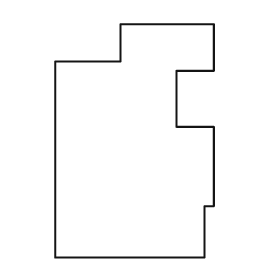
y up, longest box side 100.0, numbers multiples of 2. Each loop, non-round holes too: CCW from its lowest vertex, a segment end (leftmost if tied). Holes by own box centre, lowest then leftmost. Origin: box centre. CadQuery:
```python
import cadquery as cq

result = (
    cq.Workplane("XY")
    .moveTo(-34.0, -50.0)
    .lineTo(30.0, -50.0)
    .lineTo(30.0, -28.0)
    .lineTo(34.0, -28.0)
    .lineTo(34.0, 6.0)
    .lineTo(18.0, 6.0)
    .lineTo(18.0, 30.0)
    .lineTo(34.0, 30.0)
    .lineTo(34.0, 50.0)
    .lineTo(-6.0, 50.0)
    .lineTo(-6.0, 34.0)
    .lineTo(-34.0, 34.0)
    .close()
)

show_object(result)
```